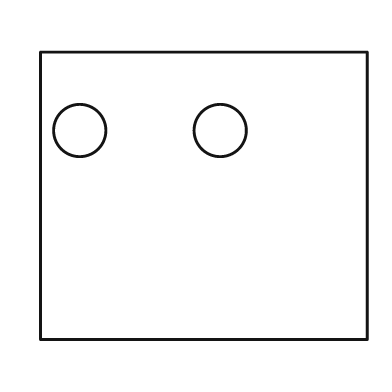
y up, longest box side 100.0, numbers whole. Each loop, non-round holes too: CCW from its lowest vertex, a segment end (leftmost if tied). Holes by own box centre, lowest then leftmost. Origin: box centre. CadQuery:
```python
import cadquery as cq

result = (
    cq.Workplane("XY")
    .moveTo(-50.0, -44.0)
    .lineTo(50.0, -44.0)
    .lineTo(50.0, 44.0)
    .lineTo(-50.0, 44.0)
    .close()
    .moveTo(-38.0, 20.0)
    .circle(8.0)
    .moveTo(5.0, 20.0)
    .circle(8.0)
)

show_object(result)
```